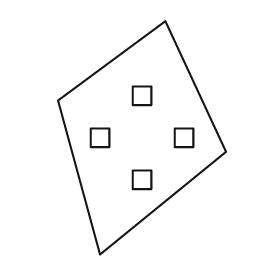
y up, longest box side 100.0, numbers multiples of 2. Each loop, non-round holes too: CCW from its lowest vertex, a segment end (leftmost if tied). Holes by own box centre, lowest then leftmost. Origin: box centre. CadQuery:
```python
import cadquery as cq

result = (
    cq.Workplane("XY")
    .moveTo(-18.0, -50.0)
    .lineTo(36.0, -6.0)
    .lineTo(10.0, 50.0)
    .lineTo(-36.0, 16.0)
    .close()
    .moveTo(-4.0, -22.0)
    .lineTo(4.0, -22.0)
    .lineTo(4.0, -14.0)
    .lineTo(-4.0, -14.0)
    .close()
    .moveTo(-22.0, -4.0)
    .lineTo(-14.0, -4.0)
    .lineTo(-14.0, 4.0)
    .lineTo(-22.0, 4.0)
    .close()
    .moveTo(14.0, -4.0)
    .lineTo(22.0, -4.0)
    .lineTo(22.0, 4.0)
    .lineTo(14.0, 4.0)
    .close()
    .moveTo(-4.0, 14.0)
    .lineTo(4.0, 14.0)
    .lineTo(4.0, 22.0)
    .lineTo(-4.0, 22.0)
    .close()
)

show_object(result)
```